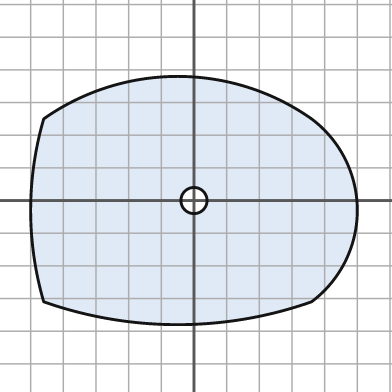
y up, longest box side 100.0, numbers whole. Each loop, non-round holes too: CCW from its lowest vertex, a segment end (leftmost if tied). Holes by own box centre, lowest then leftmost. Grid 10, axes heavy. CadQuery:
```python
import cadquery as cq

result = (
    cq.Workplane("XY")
    .moveTo(-46.0, -31.0)
    .threePointArc((-5.0, -38.0), (36.0, -31.0))
    .threePointArc((50.0, -3.0), (36.0, 25.0))
    .threePointArc((-5.0, 38.0), (-46.0, 25.0))
    .threePointArc((-50.0, -3.0), (-46.0, -31.0))
    .close()
    .moveTo(0.0, 0.0)
    .circle(4.0)
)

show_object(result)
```